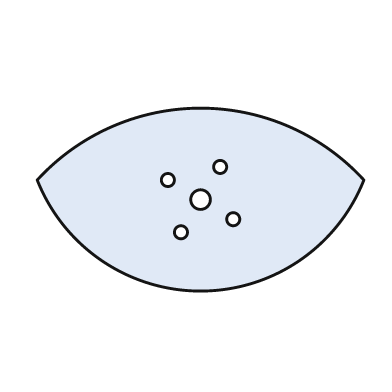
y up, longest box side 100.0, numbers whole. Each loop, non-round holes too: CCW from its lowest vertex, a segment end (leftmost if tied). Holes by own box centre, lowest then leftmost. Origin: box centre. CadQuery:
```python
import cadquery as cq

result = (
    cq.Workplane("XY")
    .moveTo(-50.0, 6.0)
    .threePointArc((0.0, -28.0), (50.0, 6.0))
    .threePointArc((0.0, 28.0), (-50.0, 6.0))
    .close()
    .moveTo(-6.0, -10.0)
    .circle(2.0)
    .moveTo(10.0, -6.0)
    .circle(2.0)
    .moveTo(0.0, 0.0)
    .circle(3.0)
    .moveTo(-10.0, 6.0)
    .circle(2.0)
    .moveTo(6.0, 10.0)
    .circle(2.0)
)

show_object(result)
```